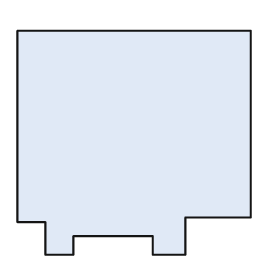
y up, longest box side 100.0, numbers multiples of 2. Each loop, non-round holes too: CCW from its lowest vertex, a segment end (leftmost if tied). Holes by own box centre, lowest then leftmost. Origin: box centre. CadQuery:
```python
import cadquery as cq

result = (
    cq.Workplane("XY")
    .moveTo(-38.0, -48.0)
    .lineTo(-26.0, -48.0)
    .lineTo(-26.0, -40.0)
    .lineTo(8.0, -40.0)
    .lineTo(8.0, -48.0)
    .lineTo(22.0, -48.0)
    .lineTo(22.0, -32.0)
    .lineTo(50.0, -32.0)
    .lineTo(50.0, 48.0)
    .lineTo(-50.0, 48.0)
    .lineTo(-50.0, -34.0)
    .lineTo(-38.0, -34.0)
    .close()
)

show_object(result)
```